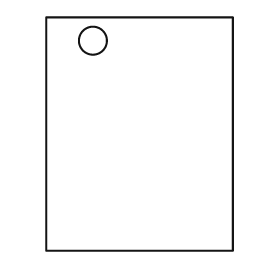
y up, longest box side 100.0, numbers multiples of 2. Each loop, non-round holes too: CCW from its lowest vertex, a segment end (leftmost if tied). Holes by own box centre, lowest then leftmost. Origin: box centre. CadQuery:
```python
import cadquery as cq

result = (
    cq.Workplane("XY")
    .moveTo(-40.0, -50.0)
    .lineTo(40.0, -50.0)
    .lineTo(40.0, 50.0)
    .lineTo(-40.0, 50.0)
    .close()
    .moveTo(-20.0, 40.0)
    .circle(6.0)
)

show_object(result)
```